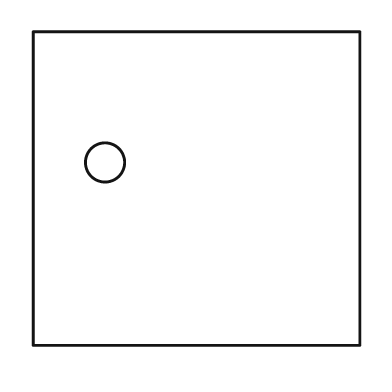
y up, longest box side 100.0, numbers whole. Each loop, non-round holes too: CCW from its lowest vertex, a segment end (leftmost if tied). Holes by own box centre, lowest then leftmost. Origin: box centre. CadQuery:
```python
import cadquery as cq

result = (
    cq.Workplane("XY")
    .moveTo(-50.0, -48.0)
    .lineTo(50.0, -48.0)
    .lineTo(50.0, 48.0)
    .lineTo(-50.0, 48.0)
    .close()
    .moveTo(-28.0, 8.0)
    .circle(6.0)
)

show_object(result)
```